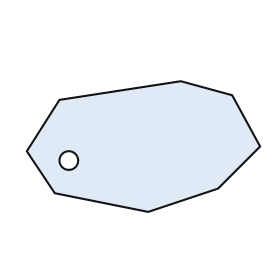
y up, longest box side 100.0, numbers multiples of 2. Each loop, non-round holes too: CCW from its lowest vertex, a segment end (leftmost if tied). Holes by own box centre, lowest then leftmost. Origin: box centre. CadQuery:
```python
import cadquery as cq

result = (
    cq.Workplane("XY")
    .moveTo(2.0, -28.0)
    .lineTo(32.0, -18.0)
    .lineTo(50.0, 0.0)
    .lineTo(38.0, 22.0)
    .lineTo(16.0, 28.0)
    .lineTo(-36.0, 20.0)
    .lineTo(-50.0, -2.0)
    .lineTo(-38.0, -20.0)
    .close()
    .moveTo(-32.0, -6.0)
    .circle(4.0)
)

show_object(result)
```